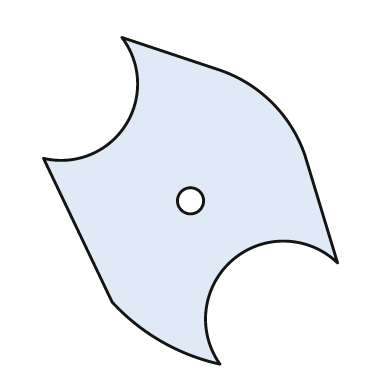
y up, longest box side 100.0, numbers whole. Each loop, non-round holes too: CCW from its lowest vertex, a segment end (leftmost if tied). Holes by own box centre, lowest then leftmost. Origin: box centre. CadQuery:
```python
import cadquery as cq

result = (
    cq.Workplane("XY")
    .moveTo(9.0, -50.0)
    .threePointArc((13.0, -18.0), (45.0, -19.0))
    .lineTo(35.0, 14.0)
    .threePointArc((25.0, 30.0), (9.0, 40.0))
    .lineTo(-21.0, 50.0)
    .threePointArc((-20.0, 23.0), (-45.0, 13.0))
    .lineTo(-24.0, -31.0)
    .threePointArc((-9.0, -43.0), (9.0, -50.0))
    .close()
    .moveTo(0.0, 0.0)
    .circle(4.0)
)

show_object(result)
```